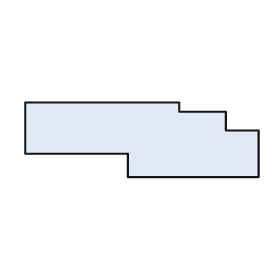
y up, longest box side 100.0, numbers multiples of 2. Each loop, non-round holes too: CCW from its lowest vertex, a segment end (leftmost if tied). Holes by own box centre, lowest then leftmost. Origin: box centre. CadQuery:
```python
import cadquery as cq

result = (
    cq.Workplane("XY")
    .moveTo(-6.0, -16.0)
    .lineTo(50.0, -16.0)
    .lineTo(50.0, 4.0)
    .lineTo(36.0, 4.0)
    .lineTo(36.0, 12.0)
    .lineTo(16.0, 12.0)
    .lineTo(16.0, 16.0)
    .lineTo(-50.0, 16.0)
    .lineTo(-50.0, -6.0)
    .lineTo(-6.0, -6.0)
    .close()
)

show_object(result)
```